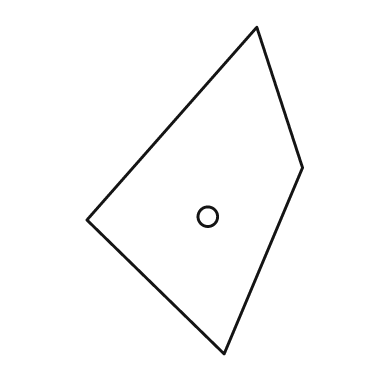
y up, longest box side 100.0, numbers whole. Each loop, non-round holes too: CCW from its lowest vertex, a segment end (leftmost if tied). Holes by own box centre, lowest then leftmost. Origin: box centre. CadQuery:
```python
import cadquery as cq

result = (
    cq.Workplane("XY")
    .moveTo(9.0, -50.0)
    .lineTo(33.0, 7.0)
    .lineTo(19.0, 50.0)
    .lineTo(-33.0, -9.0)
    .close()
    .moveTo(4.0, -8.0)
    .circle(3.0)
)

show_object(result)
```